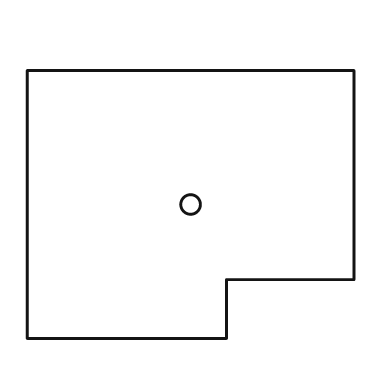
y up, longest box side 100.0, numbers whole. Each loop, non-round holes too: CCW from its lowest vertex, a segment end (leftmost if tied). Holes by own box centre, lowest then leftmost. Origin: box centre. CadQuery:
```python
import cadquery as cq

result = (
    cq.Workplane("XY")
    .moveTo(-50.0, -41.0)
    .lineTo(11.0, -41.0)
    .lineTo(11.0, -23.0)
    .lineTo(50.0, -23.0)
    .lineTo(50.0, 41.0)
    .lineTo(-50.0, 41.0)
    .close()
    .moveTo(0.0, 0.0)
    .circle(3.0)
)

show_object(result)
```